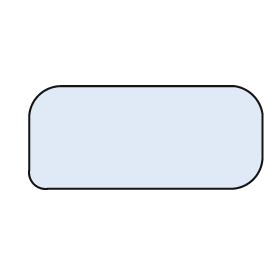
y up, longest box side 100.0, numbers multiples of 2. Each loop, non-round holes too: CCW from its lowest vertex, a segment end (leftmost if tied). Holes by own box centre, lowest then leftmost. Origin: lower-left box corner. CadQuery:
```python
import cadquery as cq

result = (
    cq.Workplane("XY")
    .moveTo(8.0, 0.0)
    .lineTo(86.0, 0.0)
    .threePointArc((96.0, 4.0), (100.0, 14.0))
    .lineTo(100.0, 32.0)
    .threePointArc((96.0, 40.0), (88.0, 44.0))
    .lineTo(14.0, 44.0)
    .threePointArc((4.0, 40.0), (0.0, 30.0))
    .lineTo(0.0, 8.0)
    .threePointArc((2.0, 2.0), (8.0, 0.0))
    .close()
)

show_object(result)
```